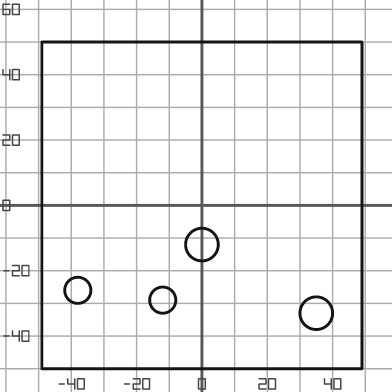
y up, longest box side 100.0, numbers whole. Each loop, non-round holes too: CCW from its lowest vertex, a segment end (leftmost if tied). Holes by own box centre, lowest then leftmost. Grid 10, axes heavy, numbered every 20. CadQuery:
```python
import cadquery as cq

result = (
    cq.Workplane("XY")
    .moveTo(-49.0, -50.0)
    .lineTo(49.0, -50.0)
    .lineTo(49.0, 50.0)
    .lineTo(-49.0, 50.0)
    .close()
    .moveTo(35.0, -33.0)
    .circle(5.0)
    .moveTo(-12.0, -29.0)
    .circle(4.0)
    .moveTo(-38.0, -26.0)
    .circle(4.0)
    .moveTo(0.0, -12.0)
    .circle(5.0)
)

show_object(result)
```